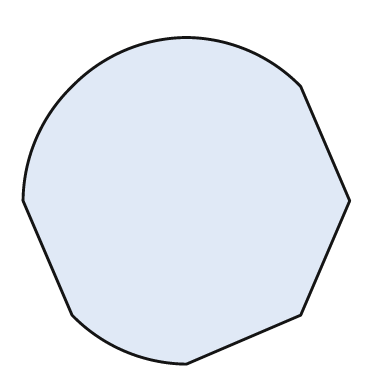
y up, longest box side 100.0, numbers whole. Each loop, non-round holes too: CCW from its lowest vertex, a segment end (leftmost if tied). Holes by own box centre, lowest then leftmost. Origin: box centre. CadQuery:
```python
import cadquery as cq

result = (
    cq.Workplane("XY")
    .moveTo(0.0, -50.0)
    .lineTo(35.0, -35.0)
    .lineTo(50.0, 0.0)
    .lineTo(35.0, 35.0)
    .threePointArc((19.0, 46.0), (0.0, 50.0))
    .threePointArc((-19.0, 46.0), (-35.0, 35.0))
    .threePointArc((-46.0, 19.0), (-50.0, 0.0))
    .lineTo(-35.0, -35.0)
    .threePointArc((-19.0, -46.0), (0.0, -50.0))
    .close()
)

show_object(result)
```